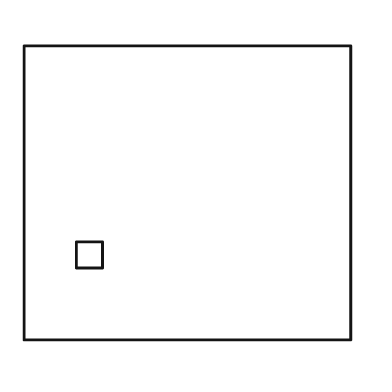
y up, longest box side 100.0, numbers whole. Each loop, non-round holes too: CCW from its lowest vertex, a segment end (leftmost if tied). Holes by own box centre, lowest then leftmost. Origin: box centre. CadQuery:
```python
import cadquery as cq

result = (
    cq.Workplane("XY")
    .moveTo(-50.0, -45.0)
    .lineTo(50.0, -45.0)
    .lineTo(50.0, 45.0)
    .lineTo(-50.0, 45.0)
    .close()
    .moveTo(-34.0, -23.0)
    .lineTo(-26.0, -23.0)
    .lineTo(-26.0, -15.0)
    .lineTo(-34.0, -15.0)
    .close()
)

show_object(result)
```